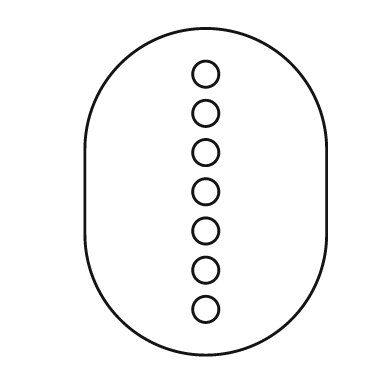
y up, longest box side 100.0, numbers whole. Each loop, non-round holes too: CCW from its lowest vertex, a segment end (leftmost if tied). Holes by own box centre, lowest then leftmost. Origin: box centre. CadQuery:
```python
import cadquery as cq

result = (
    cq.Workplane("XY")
    .moveTo(-37.0, -13.0)
    .threePointArc((0.0, -50.0), (37.0, -13.0))
    .lineTo(37.0, 13.0)
    .threePointArc((0.0, 50.0), (-37.0, 13.0))
    .close()
    .moveTo(0.0, -36.0)
    .circle(4.0)
    .moveTo(0.0, -24.0)
    .circle(4.0)
    .moveTo(0.0, -12.0)
    .circle(4.0)
    .moveTo(0.0, 0.0)
    .circle(4.0)
    .moveTo(0.0, 12.0)
    .circle(4.0)
    .moveTo(0.0, 24.0)
    .circle(4.0)
    .moveTo(0.0, 36.0)
    .circle(4.0)
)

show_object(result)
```